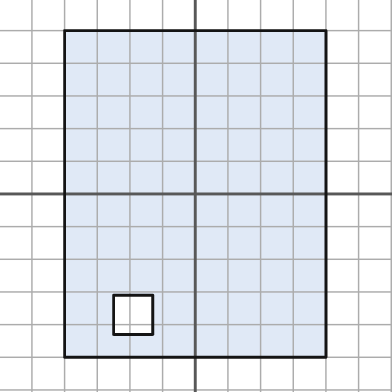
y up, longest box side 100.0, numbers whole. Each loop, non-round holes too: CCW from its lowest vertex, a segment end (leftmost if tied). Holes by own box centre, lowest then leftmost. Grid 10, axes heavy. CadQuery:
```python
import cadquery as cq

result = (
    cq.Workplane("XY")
    .moveTo(-40.0, -50.0)
    .lineTo(40.0, -50.0)
    .lineTo(40.0, 50.0)
    .lineTo(-40.0, 50.0)
    .close()
    .moveTo(-25.0, -43.0)
    .lineTo(-13.0, -43.0)
    .lineTo(-13.0, -31.0)
    .lineTo(-25.0, -31.0)
    .close()
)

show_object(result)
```